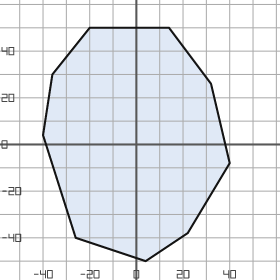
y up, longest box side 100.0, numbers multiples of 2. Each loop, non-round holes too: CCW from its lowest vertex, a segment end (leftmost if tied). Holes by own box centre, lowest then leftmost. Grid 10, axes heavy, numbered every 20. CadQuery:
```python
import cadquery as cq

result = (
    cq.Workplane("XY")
    .moveTo(4.0, -50.0)
    .lineTo(22.0, -38.0)
    .lineTo(40.0, -8.0)
    .lineTo(32.0, 26.0)
    .lineTo(14.0, 50.0)
    .lineTo(-20.0, 50.0)
    .lineTo(-36.0, 30.0)
    .lineTo(-40.0, 4.0)
    .lineTo(-26.0, -40.0)
    .close()
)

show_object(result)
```